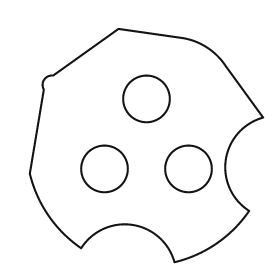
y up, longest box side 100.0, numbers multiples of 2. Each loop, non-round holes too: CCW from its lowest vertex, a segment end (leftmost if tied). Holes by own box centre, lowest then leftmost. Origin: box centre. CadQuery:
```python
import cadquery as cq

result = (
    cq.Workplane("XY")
    .moveTo(12.0, -50.0)
    .threePointArc((30.0, -42.0), (44.0, -28.0))
    .threePointArc((34.0, -6.0), (50.0, 12.0))
    .lineTo(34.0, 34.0)
    .threePointArc((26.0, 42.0), (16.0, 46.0))
    .lineTo(-12.0, 50.0)
    .lineTo(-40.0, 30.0)
    .threePointArc((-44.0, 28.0), (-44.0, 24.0))
    .lineTo(-50.0, -12.0)
    .threePointArc((-42.0, -30.0), (-28.0, -44.0))
    .threePointArc((-6.0, -34.0), (12.0, -50.0))
    .close()
    .moveTo(-18.0, -10.0)
    .circle(10.0)
    .moveTo(18.0, -10.0)
    .circle(10.0)
    .moveTo(0.0, 20.0)
    .circle(10.0)
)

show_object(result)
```